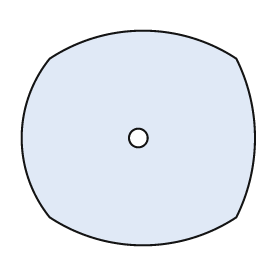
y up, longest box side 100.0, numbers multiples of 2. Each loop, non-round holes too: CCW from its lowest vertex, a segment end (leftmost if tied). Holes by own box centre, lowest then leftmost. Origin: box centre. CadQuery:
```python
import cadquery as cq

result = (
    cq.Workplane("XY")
    .moveTo(-38.0, -34.0)
    .threePointArc((2.0, -46.0), (42.0, -34.0))
    .threePointArc((50.0, 0.0), (42.0, 34.0))
    .threePointArc((2.0, 46.0), (-38.0, 34.0))
    .threePointArc((-50.0, 0.0), (-38.0, -34.0))
    .close()
    .moveTo(0.0, 0.0)
    .circle(4.0)
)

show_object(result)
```